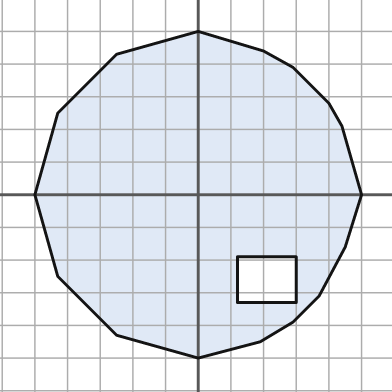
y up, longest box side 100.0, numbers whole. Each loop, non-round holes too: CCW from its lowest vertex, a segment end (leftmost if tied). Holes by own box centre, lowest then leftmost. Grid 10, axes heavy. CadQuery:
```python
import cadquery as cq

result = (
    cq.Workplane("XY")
    .moveTo(0.0, -50.0)
    .lineTo(19.0, -45.0)
    .lineTo(29.0, -39.0)
    .lineTo(37.0, -31.0)
    .lineTo(45.0, -16.0)
    .lineTo(50.0, 0.0)
    .lineTo(44.0, 21.0)
    .lineTo(40.0, 28.0)
    .lineTo(29.0, 39.0)
    .lineTo(20.0, 44.0)
    .lineTo(0.0, 50.0)
    .lineTo(-25.0, 43.0)
    .lineTo(-43.0, 25.0)
    .lineTo(-50.0, 0.0)
    .lineTo(-43.0, -25.0)
    .lineTo(-25.0, -43.0)
    .close()
    .moveTo(12.0, -33.0)
    .lineTo(30.0, -33.0)
    .lineTo(30.0, -19.0)
    .lineTo(12.0, -19.0)
    .close()
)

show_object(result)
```